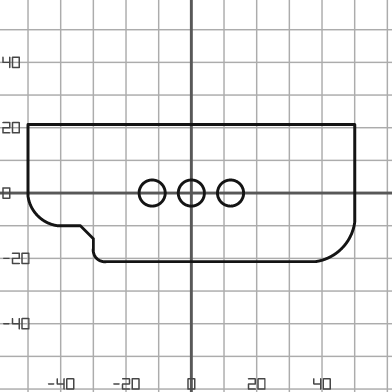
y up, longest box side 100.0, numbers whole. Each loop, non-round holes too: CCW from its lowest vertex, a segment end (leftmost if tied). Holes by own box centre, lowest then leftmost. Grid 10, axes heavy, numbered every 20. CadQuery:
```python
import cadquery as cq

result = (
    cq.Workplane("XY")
    .moveTo(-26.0, -21.0)
    .lineTo(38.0, -21.0)
    .threePointArc((46.0, -17.0), (50.0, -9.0))
    .lineTo(50.0, 21.0)
    .lineTo(-50.0, 21.0)
    .lineTo(-50.0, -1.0)
    .threePointArc((-47.0, -7.0), (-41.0, -10.0))
    .lineTo(-34.0, -10.0)
    .lineTo(-30.0, -14.0)
    .lineTo(-30.0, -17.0)
    .threePointArc((-29.0, -20.0), (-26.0, -21.0))
    .close()
    .moveTo(-12.0, 0.0)
    .circle(4.0)
    .moveTo(0.0, 0.0)
    .circle(4.0)
    .moveTo(12.0, 0.0)
    .circle(4.0)
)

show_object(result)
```